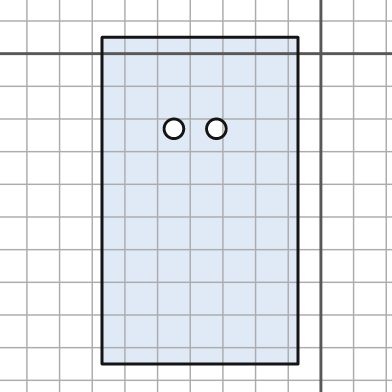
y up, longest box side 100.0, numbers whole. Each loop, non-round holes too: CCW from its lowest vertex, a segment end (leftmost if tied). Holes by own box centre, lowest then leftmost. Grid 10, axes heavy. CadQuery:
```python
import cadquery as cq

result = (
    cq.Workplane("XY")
    .moveTo(-67.0, -95.0)
    .lineTo(-7.0, -95.0)
    .lineTo(-7.0, 5.0)
    .lineTo(-67.0, 5.0)
    .close()
    .moveTo(-45.0, -23.0)
    .circle(3.0)
    .moveTo(-32.0, -23.0)
    .circle(3.0)
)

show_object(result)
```